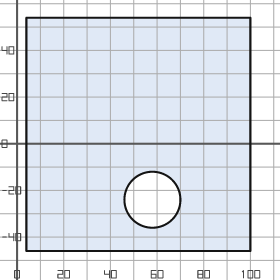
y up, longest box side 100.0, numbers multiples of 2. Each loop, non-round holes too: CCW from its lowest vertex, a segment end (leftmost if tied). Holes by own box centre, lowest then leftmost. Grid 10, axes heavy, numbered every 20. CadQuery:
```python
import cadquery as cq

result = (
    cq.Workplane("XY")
    .moveTo(4.0, -46.0)
    .lineTo(100.0, -46.0)
    .lineTo(100.0, 54.0)
    .lineTo(4.0, 54.0)
    .close()
    .moveTo(58.0, -24.0)
    .circle(12.0)
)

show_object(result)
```